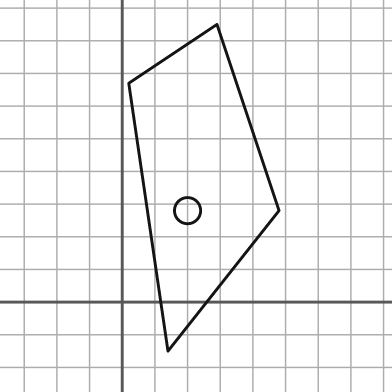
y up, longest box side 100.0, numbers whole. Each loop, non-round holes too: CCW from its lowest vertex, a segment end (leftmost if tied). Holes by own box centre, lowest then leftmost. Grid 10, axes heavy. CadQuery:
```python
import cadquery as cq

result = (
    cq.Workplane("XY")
    .moveTo(14.0, -15.0)
    .lineTo(48.0, 28.0)
    .lineTo(29.0, 85.0)
    .lineTo(2.0, 67.0)
    .close()
    .moveTo(20.0, 28.0)
    .circle(4.0)
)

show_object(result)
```